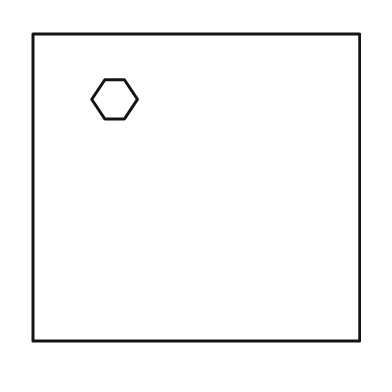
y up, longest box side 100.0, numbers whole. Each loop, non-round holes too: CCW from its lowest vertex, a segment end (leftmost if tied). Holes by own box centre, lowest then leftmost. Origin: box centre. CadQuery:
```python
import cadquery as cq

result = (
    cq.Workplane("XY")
    .moveTo(-50.0, -47.0)
    .lineTo(50.0, -47.0)
    .lineTo(50.0, 47.0)
    .lineTo(-50.0, 47.0)
    .close()
    .moveTo(-28.0, 21.0)
    .lineTo(-22.0, 21.0)
    .lineTo(-18.0, 27.0)
    .lineTo(-22.0, 33.0)
    .lineTo(-28.0, 33.0)
    .lineTo(-32.0, 27.0)
    .close()
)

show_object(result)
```